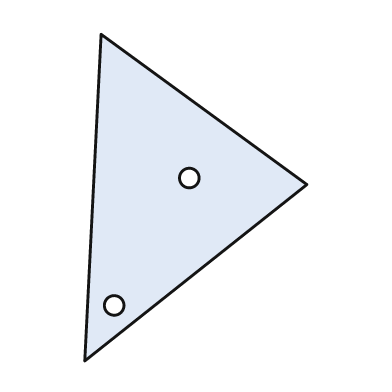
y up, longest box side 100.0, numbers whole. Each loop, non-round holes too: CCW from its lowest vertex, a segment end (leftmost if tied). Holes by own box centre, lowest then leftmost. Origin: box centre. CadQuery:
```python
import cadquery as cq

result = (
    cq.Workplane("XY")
    .moveTo(-34.0, -50.0)
    .lineTo(34.0, 4.0)
    .lineTo(-29.0, 50.0)
    .close()
    .moveTo(-25.0, -33.0)
    .circle(3.0)
    .moveTo(-2.0, 6.0)
    .circle(3.0)
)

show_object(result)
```